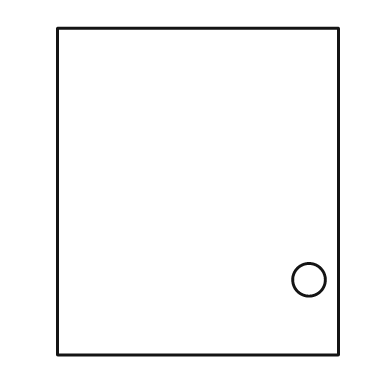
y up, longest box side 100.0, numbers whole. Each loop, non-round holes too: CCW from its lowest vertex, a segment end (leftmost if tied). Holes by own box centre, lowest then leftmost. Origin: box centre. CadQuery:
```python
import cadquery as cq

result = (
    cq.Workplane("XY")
    .moveTo(-43.0, -50.0)
    .lineTo(43.0, -50.0)
    .lineTo(43.0, 50.0)
    .lineTo(-43.0, 50.0)
    .close()
    .moveTo(34.0, -27.0)
    .circle(5.0)
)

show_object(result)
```